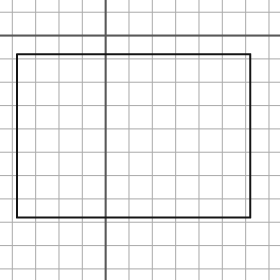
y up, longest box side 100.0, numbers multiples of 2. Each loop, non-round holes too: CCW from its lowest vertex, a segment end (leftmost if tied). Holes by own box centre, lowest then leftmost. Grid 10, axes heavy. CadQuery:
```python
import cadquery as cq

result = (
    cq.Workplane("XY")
    .moveTo(-38.0, -78.0)
    .lineTo(62.0, -78.0)
    .lineTo(62.0, -8.0)
    .lineTo(-38.0, -8.0)
    .close()
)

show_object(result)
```